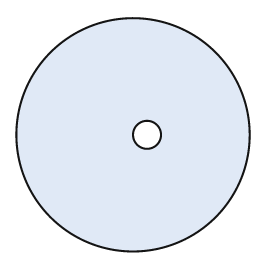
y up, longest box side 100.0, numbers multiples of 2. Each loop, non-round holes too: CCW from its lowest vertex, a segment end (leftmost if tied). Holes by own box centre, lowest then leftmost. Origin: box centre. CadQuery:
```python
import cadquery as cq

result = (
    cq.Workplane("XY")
    .moveTo(0.0, 0.0)
    .circle(50.0)
    .moveTo(6.0, 0.0)
    .circle(6.0)
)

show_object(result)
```